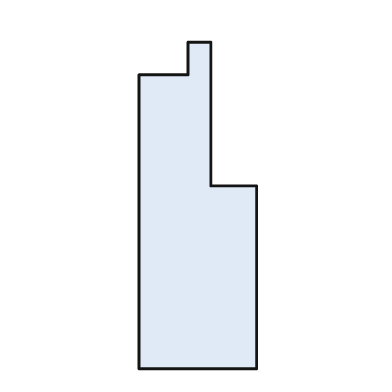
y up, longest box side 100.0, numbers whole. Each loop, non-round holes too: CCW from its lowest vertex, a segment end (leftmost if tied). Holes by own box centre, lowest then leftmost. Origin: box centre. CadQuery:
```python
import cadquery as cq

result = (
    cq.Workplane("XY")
    .moveTo(-18.0, -50.0)
    .lineTo(18.0, -50.0)
    .lineTo(18.0, 6.0)
    .lineTo(4.0, 6.0)
    .lineTo(4.0, 50.0)
    .lineTo(-3.0, 50.0)
    .lineTo(-3.0, 40.0)
    .lineTo(-18.0, 40.0)
    .close()
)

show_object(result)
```